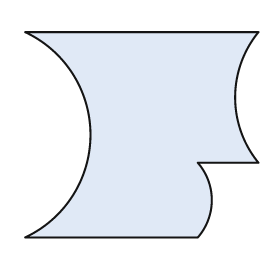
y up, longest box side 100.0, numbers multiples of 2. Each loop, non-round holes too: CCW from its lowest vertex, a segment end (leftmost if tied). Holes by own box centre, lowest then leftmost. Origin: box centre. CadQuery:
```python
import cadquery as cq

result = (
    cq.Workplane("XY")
    .moveTo(-50.0, -44.0)
    .lineTo(24.0, -44.0)
    .threePointArc((30.0, -28.0), (24.0, -12.0))
    .lineTo(50.0, -12.0)
    .threePointArc((40.0, 16.0), (50.0, 44.0))
    .lineTo(-50.0, 44.0)
    .threePointArc((-22.0, 0.0), (-50.0, -44.0))
    .close()
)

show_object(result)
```